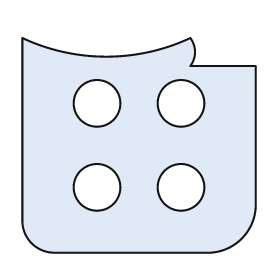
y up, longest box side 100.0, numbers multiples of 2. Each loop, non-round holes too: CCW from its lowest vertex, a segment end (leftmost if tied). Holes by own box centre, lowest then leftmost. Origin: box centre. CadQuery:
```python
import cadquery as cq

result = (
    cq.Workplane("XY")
    .moveTo(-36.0, -46.0)
    .lineTo(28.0, -46.0)
    .threePointArc((44.0, -40.0), (50.0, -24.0))
    .lineTo(50.0, 34.0)
    .lineTo(22.0, 34.0)
    .threePointArc((24.0, 40.0), (22.0, 46.0))
    .threePointArc((-14.0, 38.0), (-50.0, 46.0))
    .lineTo(-50.0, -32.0)
    .threePointArc((-46.0, -42.0), (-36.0, -46.0))
    .close()
    .moveTo(-18.0, -18.0)
    .circle(10.0)
    .moveTo(18.0, -18.0)
    .circle(10.0)
    .moveTo(-18.0, 18.0)
    .circle(10.0)
    .moveTo(18.0, 18.0)
    .circle(10.0)
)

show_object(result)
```